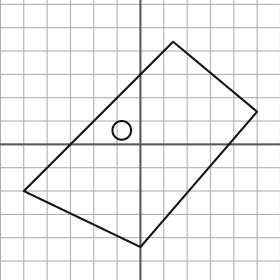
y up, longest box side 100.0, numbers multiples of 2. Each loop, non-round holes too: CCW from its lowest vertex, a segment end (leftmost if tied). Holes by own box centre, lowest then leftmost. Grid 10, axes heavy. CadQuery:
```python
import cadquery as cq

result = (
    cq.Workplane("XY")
    .moveTo(0.0, -44.0)
    .lineTo(50.0, 14.0)
    .lineTo(14.0, 44.0)
    .lineTo(-50.0, -20.0)
    .close()
    .moveTo(-8.0, 6.0)
    .circle(4.0)
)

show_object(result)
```